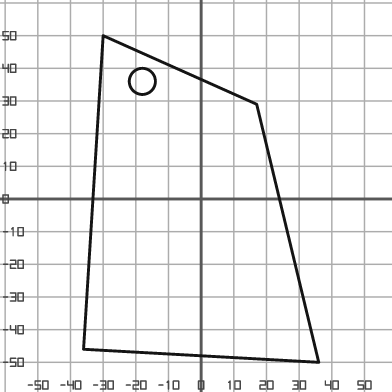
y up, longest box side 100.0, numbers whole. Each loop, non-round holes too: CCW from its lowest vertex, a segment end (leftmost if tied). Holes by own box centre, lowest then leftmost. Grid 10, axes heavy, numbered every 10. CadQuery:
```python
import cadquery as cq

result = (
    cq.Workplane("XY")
    .moveTo(36.0, -50.0)
    .lineTo(17.0, 29.0)
    .lineTo(-30.0, 50.0)
    .lineTo(-36.0, -46.0)
    .close()
    .moveTo(-18.0, 36.0)
    .circle(4.0)
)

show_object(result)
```